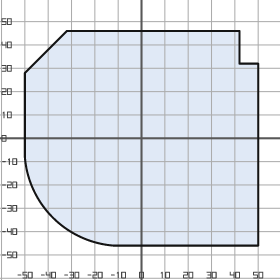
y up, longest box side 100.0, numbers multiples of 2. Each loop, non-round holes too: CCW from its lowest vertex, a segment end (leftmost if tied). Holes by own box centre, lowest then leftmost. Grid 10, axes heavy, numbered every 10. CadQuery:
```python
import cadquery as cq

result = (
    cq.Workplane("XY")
    .moveTo(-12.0, -46.0)
    .lineTo(50.0, -46.0)
    .lineTo(50.0, 32.0)
    .lineTo(42.0, 32.0)
    .lineTo(42.0, 46.0)
    .lineTo(-32.0, 46.0)
    .lineTo(-50.0, 28.0)
    .lineTo(-50.0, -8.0)
    .threePointArc((-38.0, -34.0), (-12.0, -46.0))
    .close()
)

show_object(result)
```